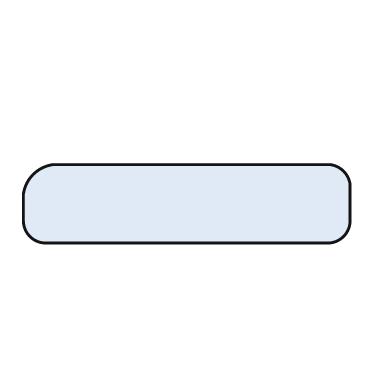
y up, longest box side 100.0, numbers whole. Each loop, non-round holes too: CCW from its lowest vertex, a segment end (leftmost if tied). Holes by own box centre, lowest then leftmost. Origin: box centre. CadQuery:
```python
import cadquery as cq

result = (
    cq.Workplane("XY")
    .moveTo(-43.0, -12.0)
    .lineTo(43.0, -12.0)
    .threePointArc((48.0, -10.0), (50.0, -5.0))
    .lineTo(50.0, 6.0)
    .threePointArc((48.0, 10.0), (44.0, 12.0))
    .lineTo(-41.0, 12.0)
    .threePointArc((-47.0, 9.0), (-50.0, 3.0))
    .lineTo(-50.0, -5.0)
    .threePointArc((-48.0, -10.0), (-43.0, -12.0))
    .close()
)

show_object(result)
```